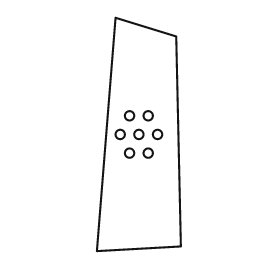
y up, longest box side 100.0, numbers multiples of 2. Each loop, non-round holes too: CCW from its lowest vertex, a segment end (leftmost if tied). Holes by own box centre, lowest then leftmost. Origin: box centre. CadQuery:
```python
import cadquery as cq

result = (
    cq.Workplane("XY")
    .moveTo(-18.0, -50.0)
    .lineTo(18.0, -48.0)
    .lineTo(16.0, 42.0)
    .lineTo(-10.0, 50.0)
    .close()
    .moveTo(-4.0, -8.0)
    .circle(2.0)
    .moveTo(4.0, -8.0)
    .circle(2.0)
    .moveTo(-8.0, 0.0)
    .circle(2.0)
    .moveTo(0.0, 0.0)
    .circle(2.0)
    .moveTo(8.0, 0.0)
    .circle(2.0)
    .moveTo(-4.0, 8.0)
    .circle(2.0)
    .moveTo(4.0, 8.0)
    .circle(2.0)
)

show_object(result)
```